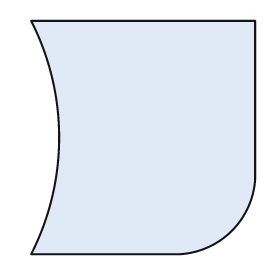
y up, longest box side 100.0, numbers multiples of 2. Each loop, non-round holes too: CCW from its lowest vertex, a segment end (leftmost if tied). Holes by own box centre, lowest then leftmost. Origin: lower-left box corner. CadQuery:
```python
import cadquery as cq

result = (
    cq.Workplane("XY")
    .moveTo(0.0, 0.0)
    .lineTo(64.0, 0.0)
    .threePointArc((86.0, 10.0), (96.0, 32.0))
    .lineTo(96.0, 100.0)
    .lineTo(0.0, 100.0)
    .threePointArc((12.0, 50.0), (0.0, 0.0))
    .close()
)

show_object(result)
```